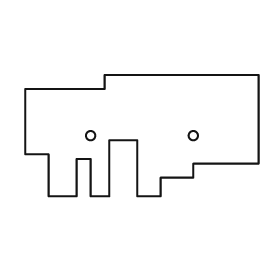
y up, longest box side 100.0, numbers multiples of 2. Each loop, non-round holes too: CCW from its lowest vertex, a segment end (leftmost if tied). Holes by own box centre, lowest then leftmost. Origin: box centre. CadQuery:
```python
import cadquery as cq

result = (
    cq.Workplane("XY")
    .moveTo(-40.0, -26.0)
    .lineTo(-28.0, -26.0)
    .lineTo(-28.0, -10.0)
    .lineTo(-22.0, -10.0)
    .lineTo(-22.0, -26.0)
    .lineTo(-14.0, -26.0)
    .lineTo(-14.0, -2.0)
    .lineTo(-2.0, -2.0)
    .lineTo(-2.0, -26.0)
    .lineTo(8.0, -26.0)
    .lineTo(8.0, -18.0)
    .lineTo(22.0, -18.0)
    .lineTo(22.0, -12.0)
    .lineTo(50.0, -12.0)
    .lineTo(50.0, 26.0)
    .lineTo(-16.0, 26.0)
    .lineTo(-16.0, 20.0)
    .lineTo(-50.0, 20.0)
    .lineTo(-50.0, -8.0)
    .lineTo(-40.0, -8.0)
    .close()
    .moveTo(-22.0, 0.0)
    .circle(2.0)
    .moveTo(22.0, 0.0)
    .circle(2.0)
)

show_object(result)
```